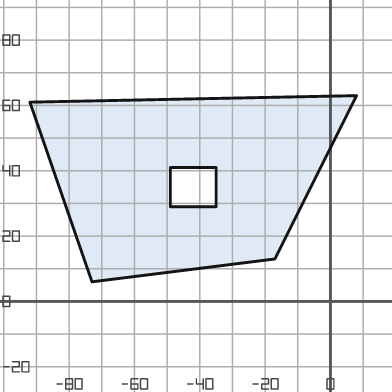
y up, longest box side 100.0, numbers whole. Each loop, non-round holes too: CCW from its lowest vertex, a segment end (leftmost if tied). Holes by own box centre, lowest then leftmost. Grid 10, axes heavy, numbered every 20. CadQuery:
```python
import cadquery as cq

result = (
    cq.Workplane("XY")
    .moveTo(-73.0, 6.0)
    .lineTo(-17.0, 13.0)
    .lineTo(8.0, 63.0)
    .lineTo(-92.0, 61.0)
    .close()
    .moveTo(-49.0, 29.0)
    .lineTo(-35.0, 29.0)
    .lineTo(-35.0, 41.0)
    .lineTo(-49.0, 41.0)
    .close()
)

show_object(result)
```